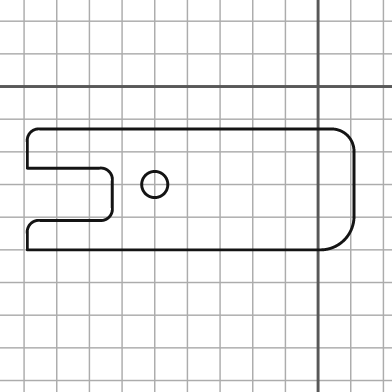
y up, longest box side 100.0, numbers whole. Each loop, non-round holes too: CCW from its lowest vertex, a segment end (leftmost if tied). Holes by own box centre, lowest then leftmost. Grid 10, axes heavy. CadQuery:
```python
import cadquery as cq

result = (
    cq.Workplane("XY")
    .moveTo(-89.0, -50.0)
    .lineTo(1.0, -50.0)
    .threePointArc((8.0, -47.0), (11.0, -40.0))
    .lineTo(11.0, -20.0)
    .threePointArc((9.0, -15.0), (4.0, -13.0))
    .lineTo(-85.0, -13.0)
    .threePointArc((-88.0, -14.0), (-89.0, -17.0))
    .lineTo(-89.0, -25.0)
    .lineTo(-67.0, -25.0)
    .threePointArc((-64.0, -26.0), (-63.0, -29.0))
    .lineTo(-63.0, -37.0)
    .threePointArc((-64.0, -40.0), (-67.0, -41.0))
    .lineTo(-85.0, -41.0)
    .threePointArc((-88.0, -42.0), (-89.0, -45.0))
    .close()
    .moveTo(-50.0, -30.0)
    .circle(4.0)
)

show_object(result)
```